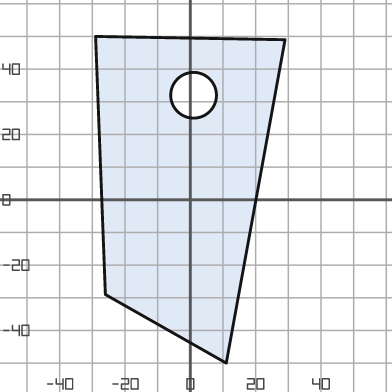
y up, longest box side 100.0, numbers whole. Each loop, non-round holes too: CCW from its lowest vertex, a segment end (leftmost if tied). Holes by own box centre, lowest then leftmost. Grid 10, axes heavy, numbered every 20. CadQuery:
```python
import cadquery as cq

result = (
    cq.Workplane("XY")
    .moveTo(11.0, -50.0)
    .lineTo(29.0, 49.0)
    .lineTo(-29.0, 50.0)
    .lineTo(-26.0, -29.0)
    .close()
    .moveTo(1.0, 32.0)
    .circle(7.0)
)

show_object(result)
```